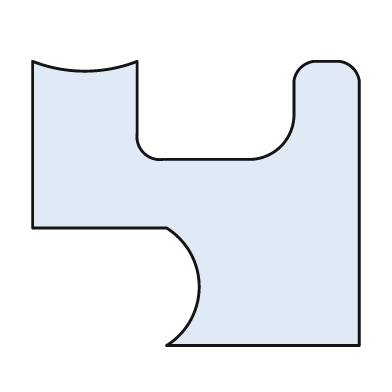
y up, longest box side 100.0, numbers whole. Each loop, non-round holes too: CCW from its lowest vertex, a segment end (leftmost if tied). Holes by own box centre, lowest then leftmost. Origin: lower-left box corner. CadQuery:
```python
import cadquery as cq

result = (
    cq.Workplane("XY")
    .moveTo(41.0, 0.0)
    .lineTo(100.0, 0.0)
    .lineTo(100.0, 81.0)
    .threePointArc((98.0, 85.0), (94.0, 87.0))
    .lineTo(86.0, 87.0)
    .threePointArc((82.0, 85.0), (80.0, 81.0))
    .lineTo(80.0, 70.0)
    .threePointArc((76.0, 61.0), (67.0, 57.0))
    .lineTo(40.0, 57.0)
    .threePointArc((34.0, 59.0), (32.0, 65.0))
    .lineTo(32.0, 87.0)
    .threePointArc((16.0, 84.0), (0.0, 87.0))
    .lineTo(0.0, 36.0)
    .lineTo(41.0, 36.0)
    .threePointArc((51.0, 18.0), (41.0, 0.0))
    .close()
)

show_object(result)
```